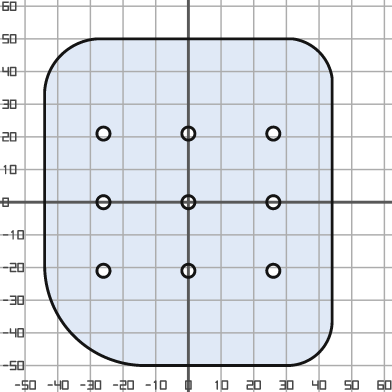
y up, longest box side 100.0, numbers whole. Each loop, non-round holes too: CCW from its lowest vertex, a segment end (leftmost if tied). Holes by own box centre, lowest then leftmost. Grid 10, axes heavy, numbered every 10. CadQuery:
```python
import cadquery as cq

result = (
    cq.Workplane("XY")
    .moveTo(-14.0, -50.0)
    .lineTo(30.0, -50.0)
    .threePointArc((40.0, -46.0), (44.0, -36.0))
    .lineTo(44.0, 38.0)
    .threePointArc((40.0, 46.0), (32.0, 50.0))
    .lineTo(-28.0, 50.0)
    .threePointArc((-39.0, 45.0), (-44.0, 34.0))
    .lineTo(-44.0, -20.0)
    .threePointArc((-35.0, -41.0), (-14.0, -50.0))
    .close()
    .moveTo(-26.0, -21.0)
    .circle(2.0)
    .moveTo(0.0, -21.0)
    .circle(2.0)
    .moveTo(26.0, -21.0)
    .circle(2.0)
    .moveTo(-26.0, 0.0)
    .circle(2.0)
    .moveTo(0.0, 0.0)
    .circle(2.0)
    .moveTo(26.0, 0.0)
    .circle(2.0)
    .moveTo(-26.0, 21.0)
    .circle(2.0)
    .moveTo(0.0, 21.0)
    .circle(2.0)
    .moveTo(26.0, 21.0)
    .circle(2.0)
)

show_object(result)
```